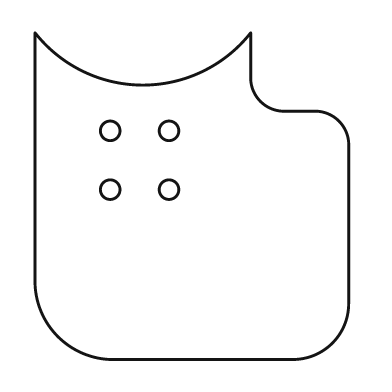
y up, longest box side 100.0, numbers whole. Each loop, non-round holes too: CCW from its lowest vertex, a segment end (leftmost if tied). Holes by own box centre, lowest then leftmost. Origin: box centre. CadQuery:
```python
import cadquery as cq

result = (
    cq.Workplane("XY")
    .moveTo(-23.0, -50.0)
    .lineTo(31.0, -50.0)
    .threePointArc((43.0, -45.0), (48.0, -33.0))
    .lineTo(48.0, 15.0)
    .threePointArc((45.0, 23.0), (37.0, 26.0))
    .lineTo(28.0, 26.0)
    .threePointArc((21.0, 29.0), (18.0, 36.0))
    .lineTo(18.0, 50.0)
    .threePointArc((-15.0, 34.0), (-48.0, 50.0))
    .lineTo(-48.0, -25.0)
    .threePointArc((-41.0, -43.0), (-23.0, -50.0))
    .close()
    .moveTo(-25.0, 2.0)
    .circle(3.0)
    .moveTo(-7.0, 2.0)
    .circle(3.0)
    .moveTo(-25.0, 20.0)
    .circle(3.0)
    .moveTo(-7.0, 20.0)
    .circle(3.0)
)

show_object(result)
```